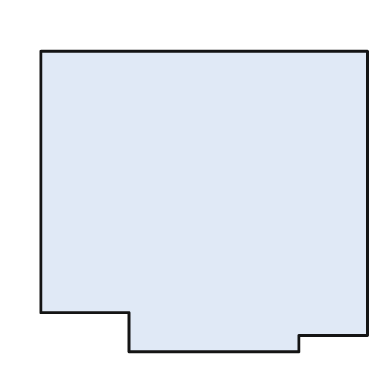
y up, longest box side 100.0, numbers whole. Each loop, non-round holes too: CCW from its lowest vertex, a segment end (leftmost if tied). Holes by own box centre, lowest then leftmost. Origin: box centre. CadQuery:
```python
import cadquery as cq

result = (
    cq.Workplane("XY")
    .moveTo(-23.0, -46.0)
    .lineTo(29.0, -46.0)
    .lineTo(29.0, -41.0)
    .lineTo(50.0, -41.0)
    .lineTo(50.0, 46.0)
    .lineTo(-50.0, 46.0)
    .lineTo(-50.0, -34.0)
    .lineTo(-23.0, -34.0)
    .close()
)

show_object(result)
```